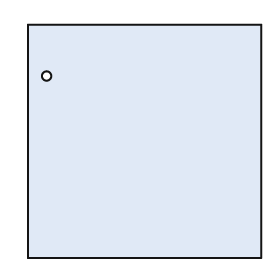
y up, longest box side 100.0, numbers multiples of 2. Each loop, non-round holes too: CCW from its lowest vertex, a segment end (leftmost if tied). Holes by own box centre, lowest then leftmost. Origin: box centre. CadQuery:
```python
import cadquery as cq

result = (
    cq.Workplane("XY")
    .moveTo(-50.0, -50.0)
    .lineTo(50.0, -50.0)
    .lineTo(50.0, 50.0)
    .lineTo(-50.0, 50.0)
    .close()
    .moveTo(-42.0, 28.0)
    .circle(2.0)
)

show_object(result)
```